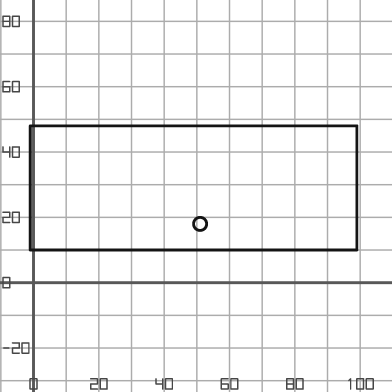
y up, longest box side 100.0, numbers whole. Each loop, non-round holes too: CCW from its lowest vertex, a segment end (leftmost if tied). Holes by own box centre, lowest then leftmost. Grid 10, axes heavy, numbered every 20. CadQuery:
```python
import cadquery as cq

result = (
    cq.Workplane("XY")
    .moveTo(-1.0, 10.0)
    .lineTo(99.0, 10.0)
    .lineTo(99.0, 48.0)
    .lineTo(-1.0, 48.0)
    .close()
    .moveTo(51.0, 18.0)
    .circle(2.0)
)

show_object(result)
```